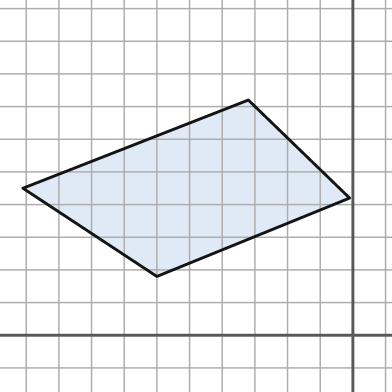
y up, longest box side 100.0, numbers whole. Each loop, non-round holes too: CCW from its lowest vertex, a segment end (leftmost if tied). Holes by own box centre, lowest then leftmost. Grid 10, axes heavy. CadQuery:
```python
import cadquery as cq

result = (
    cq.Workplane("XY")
    .moveTo(-60.0, 18.0)
    .lineTo(-1.0, 42.0)
    .lineTo(-32.0, 72.0)
    .lineTo(-101.0, 45.0)
    .close()
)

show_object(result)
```